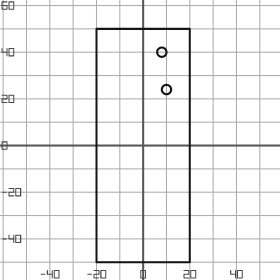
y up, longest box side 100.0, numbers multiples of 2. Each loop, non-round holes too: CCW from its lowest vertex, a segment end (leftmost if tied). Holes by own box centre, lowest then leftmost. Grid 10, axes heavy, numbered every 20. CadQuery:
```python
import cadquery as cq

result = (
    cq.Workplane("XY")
    .moveTo(-20.0, -50.0)
    .lineTo(20.0, -50.0)
    .lineTo(20.0, 50.0)
    .lineTo(-20.0, 50.0)
    .close()
    .moveTo(10.0, 24.0)
    .circle(2.0)
    .moveTo(8.0, 40.0)
    .circle(2.0)
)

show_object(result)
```